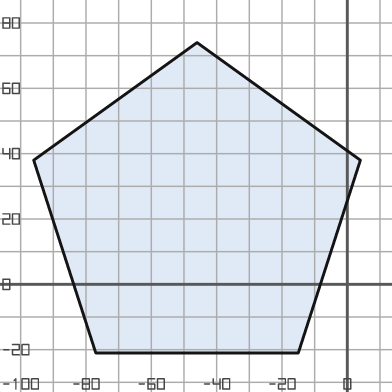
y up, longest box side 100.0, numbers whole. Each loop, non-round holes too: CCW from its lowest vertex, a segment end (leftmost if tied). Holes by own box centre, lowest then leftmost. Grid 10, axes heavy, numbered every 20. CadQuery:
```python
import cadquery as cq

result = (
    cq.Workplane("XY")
    .moveTo(-77.0, -21.0)
    .lineTo(-15.0, -21.0)
    .lineTo(4.0, 38.0)
    .lineTo(-46.0, 74.0)
    .lineTo(-96.0, 38.0)
    .close()
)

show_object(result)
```